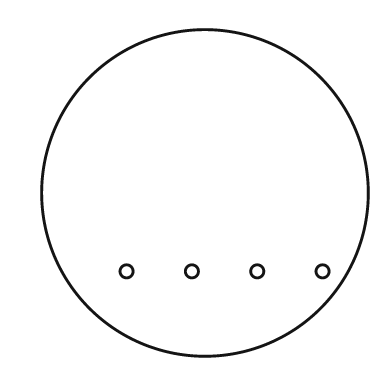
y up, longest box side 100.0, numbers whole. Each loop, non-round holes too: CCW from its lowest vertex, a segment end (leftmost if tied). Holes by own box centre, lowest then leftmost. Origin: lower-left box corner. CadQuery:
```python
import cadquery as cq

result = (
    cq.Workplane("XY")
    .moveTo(50.0, 50.0)
    .circle(50.0)
    .moveTo(26.0, 26.0)
    .circle(2.0)
    .moveTo(46.0, 26.0)
    .circle(2.0)
    .moveTo(66.0, 26.0)
    .circle(2.0)
    .moveTo(86.0, 26.0)
    .circle(2.0)
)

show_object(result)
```